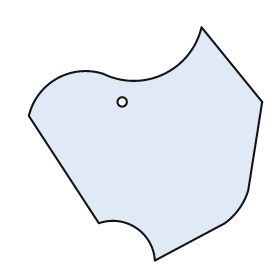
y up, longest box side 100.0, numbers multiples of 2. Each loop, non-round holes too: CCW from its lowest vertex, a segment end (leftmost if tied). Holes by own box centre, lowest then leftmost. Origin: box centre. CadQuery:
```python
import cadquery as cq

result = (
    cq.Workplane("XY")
    .moveTo(4.0, -50.0)
    .lineTo(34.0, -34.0)
    .threePointArc((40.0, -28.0), (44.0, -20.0))
    .lineTo(50.0, 18.0)
    .lineTo(24.0, 50.0)
    .threePointArc((8.0, 30.0), (-18.0, 30.0))
    .threePointArc((-38.0, 28.0), (-50.0, 12.0))
    .lineTo(-20.0, -34.0)
    .threePointArc((-4.0, -36.0), (4.0, -50.0))
    .close()
    .moveTo(-10.0, 18.0)
    .circle(2.0)
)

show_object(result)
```